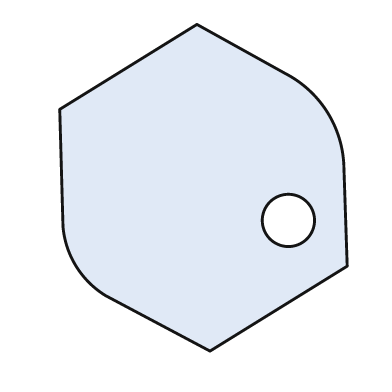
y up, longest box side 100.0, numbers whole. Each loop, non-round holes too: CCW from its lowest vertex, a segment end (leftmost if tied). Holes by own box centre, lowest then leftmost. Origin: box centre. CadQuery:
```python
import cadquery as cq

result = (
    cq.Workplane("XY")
    .moveTo(2.0, -50.0)
    .lineTo(44.0, -24.0)
    .lineTo(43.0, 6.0)
    .threePointArc((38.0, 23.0), (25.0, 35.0))
    .lineTo(-2.0, 50.0)
    .lineTo(-44.0, 24.0)
    .lineTo(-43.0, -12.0)
    .threePointArc((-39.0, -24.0), (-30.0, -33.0))
    .close()
    .moveTo(26.0, -10.0)
    .circle(8.0)
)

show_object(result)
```